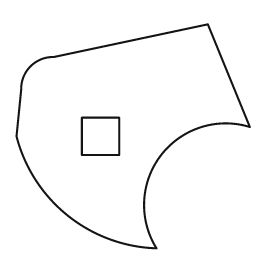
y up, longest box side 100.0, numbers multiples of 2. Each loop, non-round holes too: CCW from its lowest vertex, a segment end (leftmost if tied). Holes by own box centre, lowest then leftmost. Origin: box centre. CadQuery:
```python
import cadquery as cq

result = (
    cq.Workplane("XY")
    .moveTo(10.0, -48.0)
    .threePointArc((12.0, -8.0), (50.0, 4.0))
    .lineTo(32.0, 48.0)
    .lineTo(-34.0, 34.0)
    .threePointArc((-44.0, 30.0), (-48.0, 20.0))
    .lineTo(-50.0, 0.0)
    .threePointArc((-28.0, -34.0), (10.0, -48.0))
    .close()
    .moveTo(-22.0, -8.0)
    .lineTo(-6.0, -8.0)
    .lineTo(-6.0, 8.0)
    .lineTo(-22.0, 8.0)
    .close()
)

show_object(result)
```